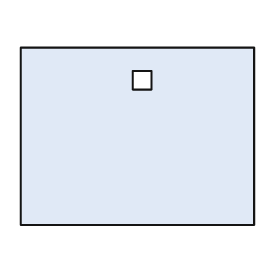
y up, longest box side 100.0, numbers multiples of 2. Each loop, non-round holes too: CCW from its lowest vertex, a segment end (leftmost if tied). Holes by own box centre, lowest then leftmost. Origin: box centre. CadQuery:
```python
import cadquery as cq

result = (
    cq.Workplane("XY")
    .moveTo(-50.0, -38.0)
    .lineTo(50.0, -38.0)
    .lineTo(50.0, 38.0)
    .lineTo(-50.0, 38.0)
    .close()
    .moveTo(-2.0, 20.0)
    .lineTo(6.0, 20.0)
    .lineTo(6.0, 28.0)
    .lineTo(-2.0, 28.0)
    .close()
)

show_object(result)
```